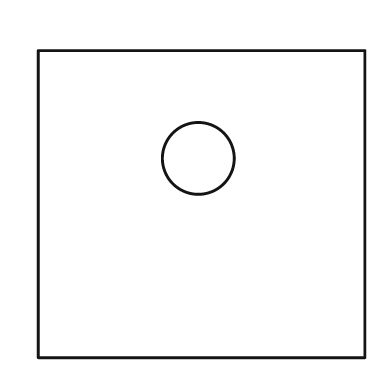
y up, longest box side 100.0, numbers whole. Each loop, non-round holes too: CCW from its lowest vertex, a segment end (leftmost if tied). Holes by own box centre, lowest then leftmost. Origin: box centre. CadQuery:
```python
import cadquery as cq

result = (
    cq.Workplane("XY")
    .moveTo(-50.0, -47.0)
    .lineTo(50.0, -47.0)
    .lineTo(50.0, 47.0)
    .lineTo(-50.0, 47.0)
    .close()
    .moveTo(-1.0, 14.0)
    .circle(11.0)
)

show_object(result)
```